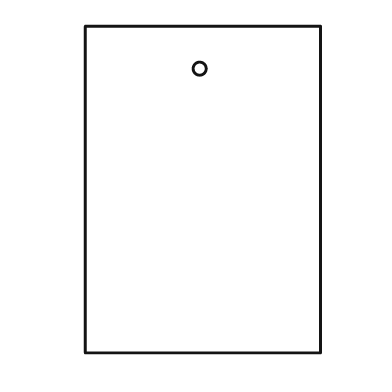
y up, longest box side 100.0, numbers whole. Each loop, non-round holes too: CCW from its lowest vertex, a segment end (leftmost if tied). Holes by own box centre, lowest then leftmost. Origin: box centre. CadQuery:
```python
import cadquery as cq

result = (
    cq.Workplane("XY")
    .moveTo(-36.0, -50.0)
    .lineTo(36.0, -50.0)
    .lineTo(36.0, 50.0)
    .lineTo(-36.0, 50.0)
    .close()
    .moveTo(-1.0, 37.0)
    .circle(2.0)
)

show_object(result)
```